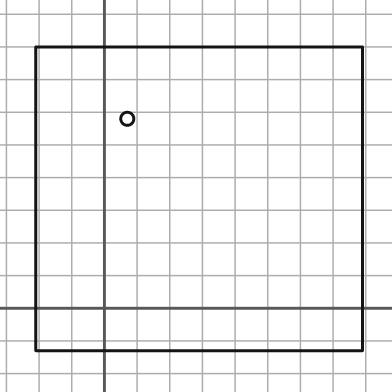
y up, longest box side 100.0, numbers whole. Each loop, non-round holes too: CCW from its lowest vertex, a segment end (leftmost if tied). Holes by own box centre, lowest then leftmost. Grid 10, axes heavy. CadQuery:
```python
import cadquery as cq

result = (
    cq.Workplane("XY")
    .moveTo(-21.0, -13.0)
    .lineTo(79.0, -13.0)
    .lineTo(79.0, 80.0)
    .lineTo(-21.0, 80.0)
    .close()
    .moveTo(7.0, 58.0)
    .circle(2.0)
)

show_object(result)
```